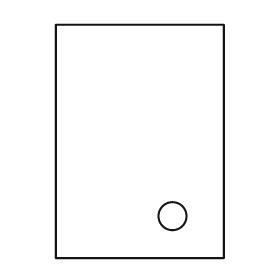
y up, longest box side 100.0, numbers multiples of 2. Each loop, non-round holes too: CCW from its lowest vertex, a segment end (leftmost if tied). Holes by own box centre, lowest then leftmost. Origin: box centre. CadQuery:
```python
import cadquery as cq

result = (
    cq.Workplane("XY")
    .moveTo(-36.0, -50.0)
    .lineTo(36.0, -50.0)
    .lineTo(36.0, 50.0)
    .lineTo(-36.0, 50.0)
    .close()
    .moveTo(14.0, -32.0)
    .circle(6.0)
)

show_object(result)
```